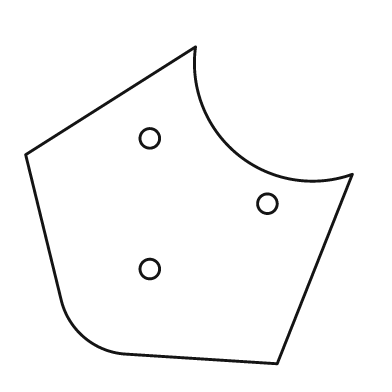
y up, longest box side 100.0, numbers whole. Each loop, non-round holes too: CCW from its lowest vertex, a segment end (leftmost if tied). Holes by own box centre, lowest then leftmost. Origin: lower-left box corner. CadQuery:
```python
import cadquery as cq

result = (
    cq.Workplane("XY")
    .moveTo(77.0, 0.0)
    .lineTo(100.0, 58.0)
    .threePointArc((65.0, 64.0), (52.0, 97.0))
    .lineTo(0.0, 64.0)
    .lineTo(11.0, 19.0)
    .threePointArc((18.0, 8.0), (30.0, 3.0))
    .close()
    .moveTo(38.0, 29.0)
    .circle(3.0)
    .moveTo(74.0, 49.0)
    .circle(3.0)
    .moveTo(38.0, 69.0)
    .circle(3.0)
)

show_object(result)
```